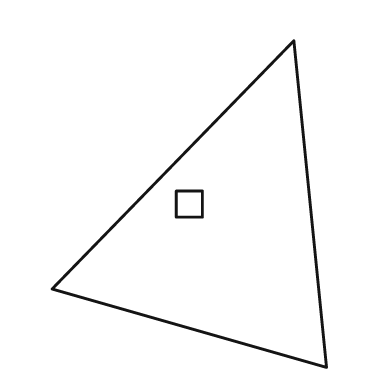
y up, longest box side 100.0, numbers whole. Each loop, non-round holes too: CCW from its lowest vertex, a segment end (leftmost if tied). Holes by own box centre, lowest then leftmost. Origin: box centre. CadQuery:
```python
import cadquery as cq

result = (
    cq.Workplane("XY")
    .moveTo(42.0, -50.0)
    .lineTo(32.0, 50.0)
    .lineTo(-42.0, -26.0)
    .close()
    .moveTo(-4.0, -4.0)
    .lineTo(4.0, -4.0)
    .lineTo(4.0, 4.0)
    .lineTo(-4.0, 4.0)
    .close()
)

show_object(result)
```